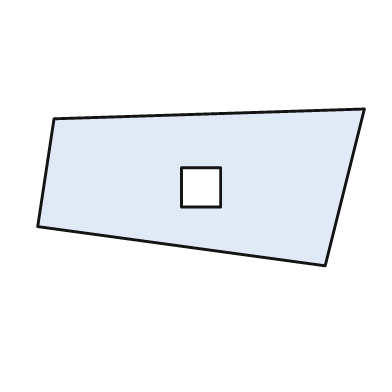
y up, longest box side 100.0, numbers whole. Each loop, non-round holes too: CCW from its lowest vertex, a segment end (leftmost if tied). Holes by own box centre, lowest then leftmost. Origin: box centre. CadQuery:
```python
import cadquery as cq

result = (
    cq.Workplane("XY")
    .moveTo(38.0, -24.0)
    .lineTo(50.0, 24.0)
    .lineTo(-45.0, 21.0)
    .lineTo(-50.0, -12.0)
    .close()
    .moveTo(-6.0, -6.0)
    .lineTo(6.0, -6.0)
    .lineTo(6.0, 6.0)
    .lineTo(-6.0, 6.0)
    .close()
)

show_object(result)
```